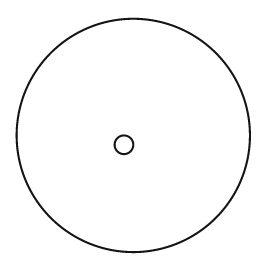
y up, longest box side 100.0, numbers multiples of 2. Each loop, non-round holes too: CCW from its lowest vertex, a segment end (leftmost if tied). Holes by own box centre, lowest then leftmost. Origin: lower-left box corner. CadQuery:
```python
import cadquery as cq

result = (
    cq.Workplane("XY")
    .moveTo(50.0, 50.0)
    .circle(50.0)
    .moveTo(46.0, 46.0)
    .circle(4.0)
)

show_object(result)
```